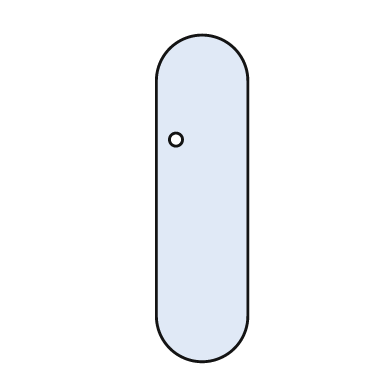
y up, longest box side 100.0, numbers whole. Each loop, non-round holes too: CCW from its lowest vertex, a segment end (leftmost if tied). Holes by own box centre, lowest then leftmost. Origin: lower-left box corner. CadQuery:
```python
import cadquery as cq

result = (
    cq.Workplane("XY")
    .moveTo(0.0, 14.0)
    .threePointArc((14.0, 0.0), (28.0, 14.0))
    .lineTo(28.0, 86.0)
    .threePointArc((14.0, 100.0), (0.0, 86.0))
    .close()
    .moveTo(6.0, 68.0)
    .circle(2.0)
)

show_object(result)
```